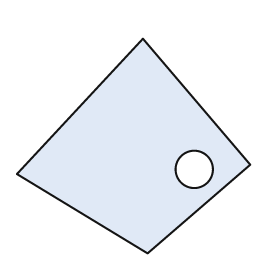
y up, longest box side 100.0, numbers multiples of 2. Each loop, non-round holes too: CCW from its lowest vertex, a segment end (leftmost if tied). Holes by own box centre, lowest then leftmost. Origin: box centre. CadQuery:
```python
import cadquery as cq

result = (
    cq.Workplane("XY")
    .moveTo(6.0, -46.0)
    .lineTo(50.0, -8.0)
    .lineTo(4.0, 46.0)
    .lineTo(-50.0, -12.0)
    .close()
    .moveTo(26.0, -10.0)
    .circle(8.0)
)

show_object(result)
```